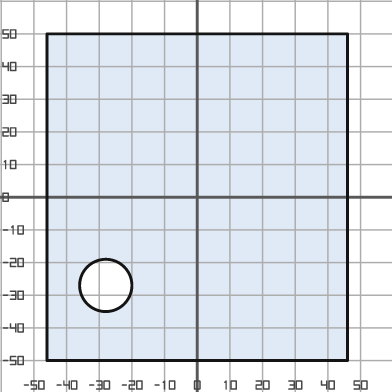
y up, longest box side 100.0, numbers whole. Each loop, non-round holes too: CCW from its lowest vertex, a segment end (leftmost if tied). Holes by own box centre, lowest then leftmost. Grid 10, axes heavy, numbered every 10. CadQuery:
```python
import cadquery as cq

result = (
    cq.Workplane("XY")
    .moveTo(-46.0, -50.0)
    .lineTo(46.0, -50.0)
    .lineTo(46.0, 50.0)
    .lineTo(-46.0, 50.0)
    .close()
    .moveTo(-28.0, -27.0)
    .circle(8.0)
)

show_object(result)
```